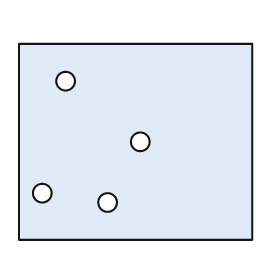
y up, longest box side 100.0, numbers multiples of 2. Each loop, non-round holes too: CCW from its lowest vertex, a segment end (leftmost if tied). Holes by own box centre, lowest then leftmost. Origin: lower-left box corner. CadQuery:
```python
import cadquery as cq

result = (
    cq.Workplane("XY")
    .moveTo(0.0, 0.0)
    .lineTo(100.0, 0.0)
    .lineTo(100.0, 84.0)
    .lineTo(0.0, 84.0)
    .close()
    .moveTo(38.0, 16.0)
    .circle(4.0)
    .moveTo(10.0, 20.0)
    .circle(4.0)
    .moveTo(52.0, 42.0)
    .circle(4.0)
    .moveTo(20.0, 68.0)
    .circle(4.0)
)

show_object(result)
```